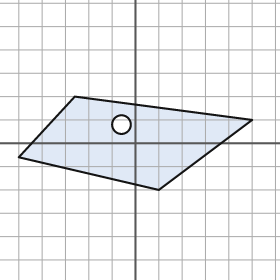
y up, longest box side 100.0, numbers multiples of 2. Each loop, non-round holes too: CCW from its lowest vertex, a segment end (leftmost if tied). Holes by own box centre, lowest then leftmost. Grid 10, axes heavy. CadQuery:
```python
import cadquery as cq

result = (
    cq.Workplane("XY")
    .moveTo(10.0, -20.0)
    .lineTo(50.0, 10.0)
    .lineTo(-26.0, 20.0)
    .lineTo(-50.0, -6.0)
    .close()
    .moveTo(-6.0, 8.0)
    .circle(4.0)
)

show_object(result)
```